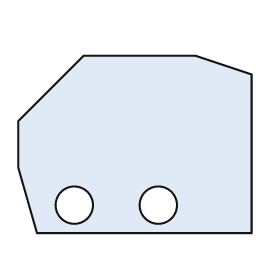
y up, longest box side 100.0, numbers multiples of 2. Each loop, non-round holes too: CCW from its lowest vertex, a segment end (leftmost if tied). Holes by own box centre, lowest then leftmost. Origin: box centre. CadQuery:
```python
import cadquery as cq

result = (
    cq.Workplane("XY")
    .moveTo(-42.0, -38.0)
    .lineTo(50.0, -38.0)
    .lineTo(50.0, 30.0)
    .lineTo(26.0, 38.0)
    .lineTo(-22.0, 38.0)
    .lineTo(-50.0, 10.0)
    .lineTo(-50.0, -10.0)
    .close()
    .moveTo(-26.0, -26.0)
    .circle(8.0)
    .moveTo(10.0, -26.0)
    .circle(8.0)
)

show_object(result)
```